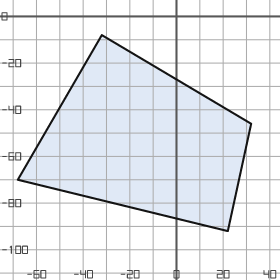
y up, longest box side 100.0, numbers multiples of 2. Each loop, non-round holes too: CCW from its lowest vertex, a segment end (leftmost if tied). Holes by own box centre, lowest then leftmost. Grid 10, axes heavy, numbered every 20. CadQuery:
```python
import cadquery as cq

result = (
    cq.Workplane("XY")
    .moveTo(22.0, -92.0)
    .lineTo(32.0, -46.0)
    .lineTo(-32.0, -8.0)
    .lineTo(-68.0, -70.0)
    .close()
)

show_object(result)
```